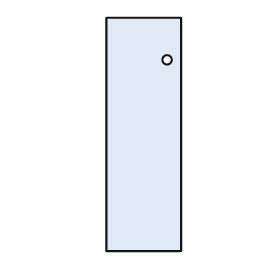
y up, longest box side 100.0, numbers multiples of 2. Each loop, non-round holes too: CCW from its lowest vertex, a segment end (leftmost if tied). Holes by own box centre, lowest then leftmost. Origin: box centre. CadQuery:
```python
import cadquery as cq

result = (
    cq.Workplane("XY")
    .moveTo(-16.0, -50.0)
    .lineTo(16.0, -50.0)
    .lineTo(16.0, 50.0)
    .lineTo(-16.0, 50.0)
    .close()
    .moveTo(10.0, 32.0)
    .circle(2.0)
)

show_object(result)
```